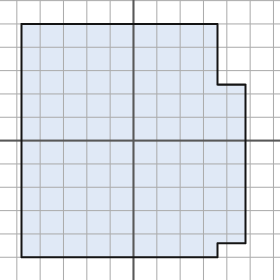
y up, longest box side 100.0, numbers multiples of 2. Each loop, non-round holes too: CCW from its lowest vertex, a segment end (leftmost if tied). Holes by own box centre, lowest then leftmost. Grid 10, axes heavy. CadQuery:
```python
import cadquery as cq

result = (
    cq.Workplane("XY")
    .moveTo(-48.0, -50.0)
    .lineTo(36.0, -50.0)
    .lineTo(36.0, -44.0)
    .lineTo(48.0, -44.0)
    .lineTo(48.0, 24.0)
    .lineTo(36.0, 24.0)
    .lineTo(36.0, 50.0)
    .lineTo(-48.0, 50.0)
    .close()
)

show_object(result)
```